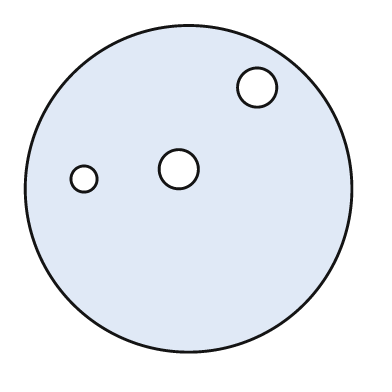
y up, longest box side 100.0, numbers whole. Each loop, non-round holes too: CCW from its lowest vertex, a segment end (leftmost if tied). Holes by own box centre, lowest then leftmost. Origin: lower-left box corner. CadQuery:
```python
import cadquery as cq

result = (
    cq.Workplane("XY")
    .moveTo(50.0, 50.0)
    .circle(50.0)
    .moveTo(18.0, 53.0)
    .circle(4.0)
    .moveTo(47.0, 56.0)
    .circle(6.0)
    .moveTo(71.0, 81.0)
    .circle(6.0)
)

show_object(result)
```